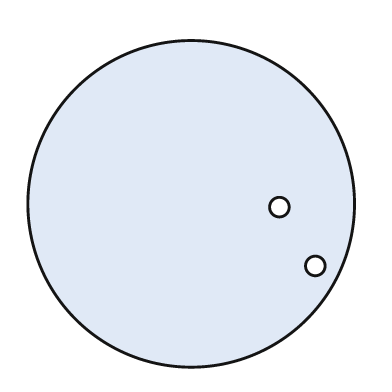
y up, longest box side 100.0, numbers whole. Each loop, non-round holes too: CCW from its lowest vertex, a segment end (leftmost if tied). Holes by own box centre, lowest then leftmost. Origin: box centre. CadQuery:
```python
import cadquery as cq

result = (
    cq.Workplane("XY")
    .moveTo(0.0, 0.0)
    .circle(50.0)
    .moveTo(38.0, -19.0)
    .circle(3.0)
    .moveTo(27.0, -1.0)
    .circle(3.0)
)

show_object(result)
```